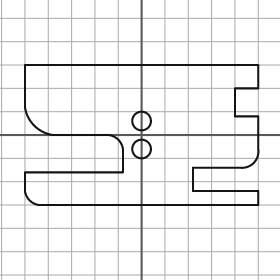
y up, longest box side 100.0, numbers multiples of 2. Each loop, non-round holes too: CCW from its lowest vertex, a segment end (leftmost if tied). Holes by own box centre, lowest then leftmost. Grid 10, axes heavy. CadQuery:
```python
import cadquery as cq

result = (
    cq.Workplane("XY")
    .moveTo(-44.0, -30.0)
    .lineTo(50.0, -30.0)
    .lineTo(50.0, -24.0)
    .lineTo(22.0, -24.0)
    .lineTo(22.0, -14.0)
    .lineTo(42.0, -14.0)
    .threePointArc((48.0, -12.0), (50.0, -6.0))
    .lineTo(50.0, 8.0)
    .lineTo(40.0, 8.0)
    .lineTo(40.0, 20.0)
    .lineTo(50.0, 20.0)
    .lineTo(50.0, 30.0)
    .lineTo(-50.0, 30.0)
    .lineTo(-50.0, 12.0)
    .threePointArc((-46.0, 4.0), (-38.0, 0.0))
    .lineTo(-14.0, 0.0)
    .threePointArc((-10.0, -2.0), (-8.0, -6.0))
    .lineTo(-8.0, -16.0)
    .lineTo(-50.0, -16.0)
    .lineTo(-50.0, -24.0)
    .threePointArc((-48.0, -28.0), (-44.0, -30.0))
    .close()
    .moveTo(0.0, -6.0)
    .circle(4.0)
    .moveTo(0.0, 6.0)
    .circle(4.0)
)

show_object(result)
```